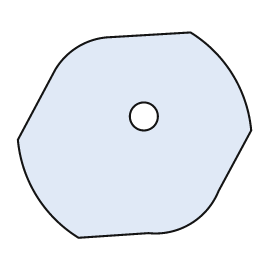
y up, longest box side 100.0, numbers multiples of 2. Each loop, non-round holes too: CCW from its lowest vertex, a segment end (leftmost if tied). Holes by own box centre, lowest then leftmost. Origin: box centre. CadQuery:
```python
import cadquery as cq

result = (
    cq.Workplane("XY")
    .moveTo(-24.0, -44.0)
    .lineTo(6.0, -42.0)
    .threePointArc((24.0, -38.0), (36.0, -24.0))
    .lineTo(50.0, 2.0)
    .threePointArc((42.0, 26.0), (24.0, 44.0))
    .lineTo(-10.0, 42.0)
    .threePointArc((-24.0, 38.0), (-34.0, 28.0))
    .lineTo(-50.0, -2.0)
    .threePointArc((-42.0, -26.0), (-24.0, -44.0))
    .close()
    .moveTo(4.0, 8.0)
    .circle(6.0)
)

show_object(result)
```